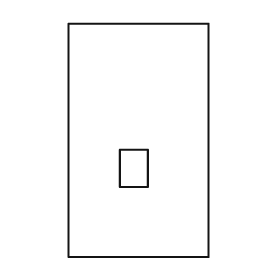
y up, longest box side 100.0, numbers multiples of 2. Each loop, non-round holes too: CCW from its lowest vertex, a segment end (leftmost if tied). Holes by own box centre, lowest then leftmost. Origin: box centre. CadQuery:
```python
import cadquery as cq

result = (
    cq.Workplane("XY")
    .moveTo(-30.0, -50.0)
    .lineTo(30.0, -50.0)
    .lineTo(30.0, 50.0)
    .lineTo(-30.0, 50.0)
    .close()
    .moveTo(-8.0, -20.0)
    .lineTo(4.0, -20.0)
    .lineTo(4.0, -4.0)
    .lineTo(-8.0, -4.0)
    .close()
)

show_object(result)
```